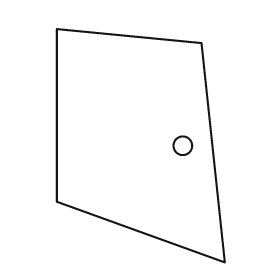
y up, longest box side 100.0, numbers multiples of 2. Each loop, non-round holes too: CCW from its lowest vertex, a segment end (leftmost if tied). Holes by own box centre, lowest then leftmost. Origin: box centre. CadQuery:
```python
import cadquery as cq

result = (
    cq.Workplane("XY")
    .moveTo(36.0, -50.0)
    .lineTo(26.0, 44.0)
    .lineTo(-36.0, 50.0)
    .lineTo(-36.0, -24.0)
    .close()
    .moveTo(18.0, 0.0)
    .circle(4.0)
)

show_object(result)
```